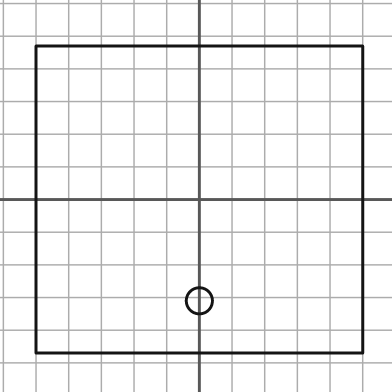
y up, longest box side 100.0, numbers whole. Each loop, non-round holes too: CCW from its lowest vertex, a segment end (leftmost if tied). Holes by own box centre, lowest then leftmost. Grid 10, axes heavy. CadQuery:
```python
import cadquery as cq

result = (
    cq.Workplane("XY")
    .moveTo(-50.0, -47.0)
    .lineTo(50.0, -47.0)
    .lineTo(50.0, 47.0)
    .lineTo(-50.0, 47.0)
    .close()
    .moveTo(0.0, -31.0)
    .circle(4.0)
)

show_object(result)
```